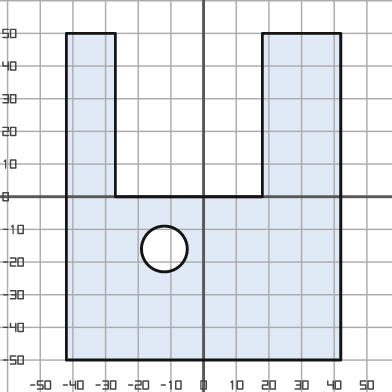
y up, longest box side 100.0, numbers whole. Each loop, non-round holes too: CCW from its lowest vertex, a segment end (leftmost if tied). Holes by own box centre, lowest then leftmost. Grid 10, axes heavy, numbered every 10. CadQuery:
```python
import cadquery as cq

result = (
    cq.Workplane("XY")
    .moveTo(-42.0, -50.0)
    .lineTo(42.0, -50.0)
    .lineTo(42.0, 50.0)
    .lineTo(18.0, 50.0)
    .lineTo(18.0, 0.0)
    .lineTo(-27.0, 0.0)
    .lineTo(-27.0, 50.0)
    .lineTo(-42.0, 50.0)
    .close()
    .moveTo(-12.0, -16.0)
    .circle(7.0)
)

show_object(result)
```